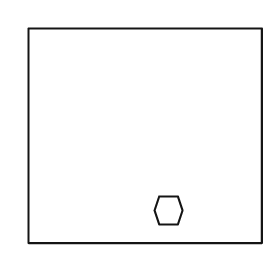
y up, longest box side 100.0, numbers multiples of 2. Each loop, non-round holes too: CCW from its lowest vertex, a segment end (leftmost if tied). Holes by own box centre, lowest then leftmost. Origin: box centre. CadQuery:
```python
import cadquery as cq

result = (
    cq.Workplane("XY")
    .moveTo(-50.0, -46.0)
    .lineTo(50.0, -46.0)
    .lineTo(50.0, 46.0)
    .lineTo(-50.0, 46.0)
    .close()
    .moveTo(6.0, -38.0)
    .lineTo(14.0, -38.0)
    .lineTo(16.0, -32.0)
    .lineTo(14.0, -26.0)
    .lineTo(6.0, -26.0)
    .lineTo(4.0, -32.0)
    .close()
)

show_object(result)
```